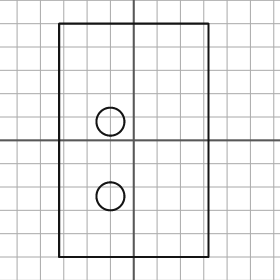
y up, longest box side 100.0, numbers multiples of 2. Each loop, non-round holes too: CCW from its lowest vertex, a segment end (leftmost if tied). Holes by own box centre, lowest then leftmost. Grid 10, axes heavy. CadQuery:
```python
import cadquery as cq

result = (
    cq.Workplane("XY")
    .moveTo(-32.0, -50.0)
    .lineTo(32.0, -50.0)
    .lineTo(32.0, 50.0)
    .lineTo(-32.0, 50.0)
    .close()
    .moveTo(-10.0, -24.0)
    .circle(6.0)
    .moveTo(-10.0, 8.0)
    .circle(6.0)
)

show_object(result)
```